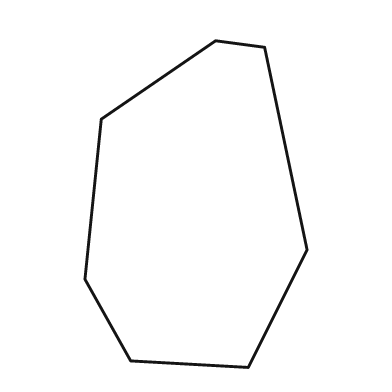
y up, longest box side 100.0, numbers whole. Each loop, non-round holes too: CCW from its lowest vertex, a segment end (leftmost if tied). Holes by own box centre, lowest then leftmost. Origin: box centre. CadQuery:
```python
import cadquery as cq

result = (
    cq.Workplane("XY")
    .moveTo(16.0, -50.0)
    .lineTo(34.0, -14.0)
    .lineTo(21.0, 48.0)
    .lineTo(6.0, 50.0)
    .lineTo(-29.0, 26.0)
    .lineTo(-34.0, -23.0)
    .lineTo(-20.0, -48.0)
    .close()
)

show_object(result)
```